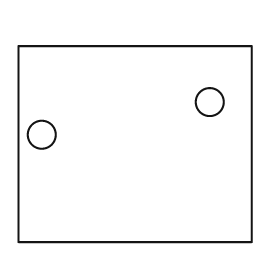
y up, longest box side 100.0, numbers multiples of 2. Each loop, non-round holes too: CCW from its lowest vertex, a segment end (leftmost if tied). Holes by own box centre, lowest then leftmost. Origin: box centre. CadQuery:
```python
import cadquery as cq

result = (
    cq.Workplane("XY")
    .moveTo(-50.0, -42.0)
    .lineTo(50.0, -42.0)
    .lineTo(50.0, 42.0)
    .lineTo(-50.0, 42.0)
    .close()
    .moveTo(-40.0, 4.0)
    .circle(6.0)
    .moveTo(32.0, 18.0)
    .circle(6.0)
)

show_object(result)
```